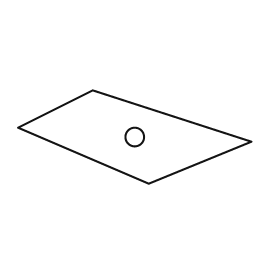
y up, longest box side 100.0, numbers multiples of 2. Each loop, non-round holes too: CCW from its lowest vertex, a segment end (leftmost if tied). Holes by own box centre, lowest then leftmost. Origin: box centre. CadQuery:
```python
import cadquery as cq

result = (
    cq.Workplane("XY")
    .moveTo(6.0, -20.0)
    .lineTo(50.0, -2.0)
    .lineTo(-18.0, 20.0)
    .lineTo(-50.0, 4.0)
    .close()
    .moveTo(0.0, 0.0)
    .circle(4.0)
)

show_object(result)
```